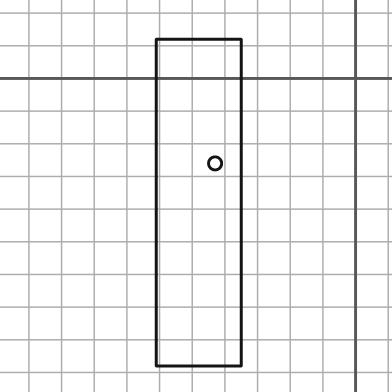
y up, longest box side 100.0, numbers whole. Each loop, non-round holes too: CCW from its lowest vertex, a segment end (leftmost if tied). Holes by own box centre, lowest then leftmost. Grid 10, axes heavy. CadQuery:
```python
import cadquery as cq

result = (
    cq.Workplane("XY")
    .moveTo(-61.0, -88.0)
    .lineTo(-35.0, -88.0)
    .lineTo(-35.0, 12.0)
    .lineTo(-61.0, 12.0)
    .close()
    .moveTo(-43.0, -26.0)
    .circle(2.0)
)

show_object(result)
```